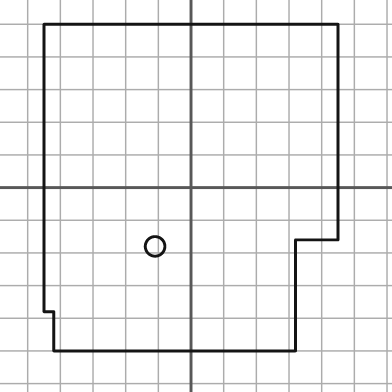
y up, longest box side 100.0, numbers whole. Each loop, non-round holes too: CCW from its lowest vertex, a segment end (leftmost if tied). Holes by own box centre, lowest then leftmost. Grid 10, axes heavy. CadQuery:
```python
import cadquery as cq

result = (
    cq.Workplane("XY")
    .moveTo(-42.0, -50.0)
    .lineTo(32.0, -50.0)
    .lineTo(32.0, -16.0)
    .lineTo(45.0, -16.0)
    .lineTo(45.0, 50.0)
    .lineTo(-45.0, 50.0)
    .lineTo(-45.0, -38.0)
    .lineTo(-42.0, -38.0)
    .close()
    .moveTo(-11.0, -18.0)
    .circle(3.0)
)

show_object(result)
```